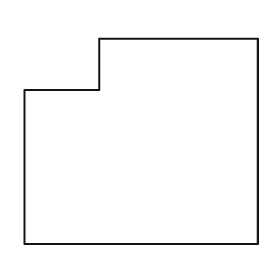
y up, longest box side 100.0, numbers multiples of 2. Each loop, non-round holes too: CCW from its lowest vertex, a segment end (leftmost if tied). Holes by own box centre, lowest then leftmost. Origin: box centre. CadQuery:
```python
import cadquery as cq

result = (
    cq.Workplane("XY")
    .moveTo(-50.0, -44.0)
    .lineTo(50.0, -44.0)
    .lineTo(50.0, 44.0)
    .lineTo(-18.0, 44.0)
    .lineTo(-18.0, 22.0)
    .lineTo(-50.0, 22.0)
    .close()
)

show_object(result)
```